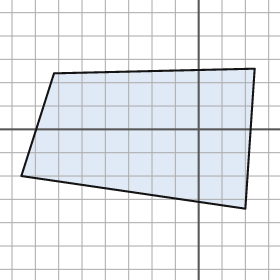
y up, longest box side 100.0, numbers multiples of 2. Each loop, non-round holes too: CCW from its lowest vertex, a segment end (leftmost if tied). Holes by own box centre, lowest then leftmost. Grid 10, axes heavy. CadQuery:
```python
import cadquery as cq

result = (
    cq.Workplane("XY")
    .moveTo(20.0, -34.0)
    .lineTo(24.0, 26.0)
    .lineTo(-62.0, 24.0)
    .lineTo(-76.0, -20.0)
    .close()
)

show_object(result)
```